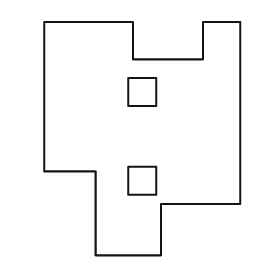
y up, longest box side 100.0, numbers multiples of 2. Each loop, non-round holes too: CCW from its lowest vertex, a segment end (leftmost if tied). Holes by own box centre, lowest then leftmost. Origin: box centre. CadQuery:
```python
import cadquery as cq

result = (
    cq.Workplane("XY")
    .moveTo(-20.0, -50.0)
    .lineTo(8.0, -50.0)
    .lineTo(8.0, -28.0)
    .lineTo(42.0, -28.0)
    .lineTo(42.0, 50.0)
    .lineTo(26.0, 50.0)
    .lineTo(26.0, 34.0)
    .lineTo(-4.0, 34.0)
    .lineTo(-4.0, 50.0)
    .lineTo(-42.0, 50.0)
    .lineTo(-42.0, -14.0)
    .lineTo(-20.0, -14.0)
    .close()
    .moveTo(-6.0, -24.0)
    .lineTo(6.0, -24.0)
    .lineTo(6.0, -12.0)
    .lineTo(-6.0, -12.0)
    .close()
    .moveTo(-6.0, 14.0)
    .lineTo(6.0, 14.0)
    .lineTo(6.0, 26.0)
    .lineTo(-6.0, 26.0)
    .close()
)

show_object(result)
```